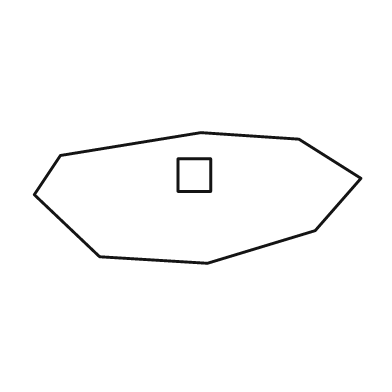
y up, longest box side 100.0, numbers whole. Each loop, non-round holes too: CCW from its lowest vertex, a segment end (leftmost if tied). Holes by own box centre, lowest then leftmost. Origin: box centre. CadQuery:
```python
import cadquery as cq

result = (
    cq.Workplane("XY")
    .moveTo(3.0, -20.0)
    .lineTo(36.0, -10.0)
    .lineTo(50.0, 6.0)
    .lineTo(31.0, 18.0)
    .lineTo(1.0, 20.0)
    .lineTo(-42.0, 13.0)
    .lineTo(-50.0, 1.0)
    .lineTo(-30.0, -18.0)
    .close()
    .moveTo(-6.0, 2.0)
    .lineTo(4.0, 2.0)
    .lineTo(4.0, 12.0)
    .lineTo(-6.0, 12.0)
    .close()
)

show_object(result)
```